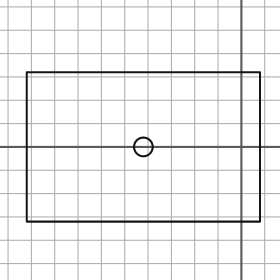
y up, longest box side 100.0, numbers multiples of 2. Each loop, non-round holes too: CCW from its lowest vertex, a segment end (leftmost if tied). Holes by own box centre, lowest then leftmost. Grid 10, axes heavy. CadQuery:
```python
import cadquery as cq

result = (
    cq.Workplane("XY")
    .moveTo(-92.0, -32.0)
    .lineTo(8.0, -32.0)
    .lineTo(8.0, 32.0)
    .lineTo(-92.0, 32.0)
    .close()
    .moveTo(-42.0, 0.0)
    .circle(4.0)
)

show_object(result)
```